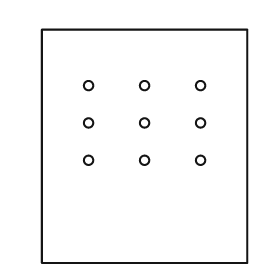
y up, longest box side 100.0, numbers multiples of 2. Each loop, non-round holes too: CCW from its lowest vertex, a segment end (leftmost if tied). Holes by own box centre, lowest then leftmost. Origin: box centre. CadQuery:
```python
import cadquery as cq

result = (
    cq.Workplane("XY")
    .moveTo(-44.0, -50.0)
    .lineTo(44.0, -50.0)
    .lineTo(44.0, 50.0)
    .lineTo(-44.0, 50.0)
    .close()
    .moveTo(-24.0, -6.0)
    .circle(2.0)
    .moveTo(0.0, -6.0)
    .circle(2.0)
    .moveTo(24.0, -6.0)
    .circle(2.0)
    .moveTo(-24.0, 10.0)
    .circle(2.0)
    .moveTo(0.0, 10.0)
    .circle(2.0)
    .moveTo(24.0, 10.0)
    .circle(2.0)
    .moveTo(-24.0, 26.0)
    .circle(2.0)
    .moveTo(0.0, 26.0)
    .circle(2.0)
    .moveTo(24.0, 26.0)
    .circle(2.0)
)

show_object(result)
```